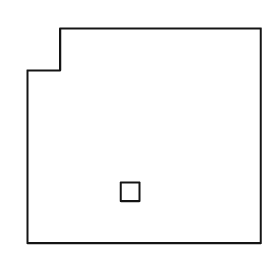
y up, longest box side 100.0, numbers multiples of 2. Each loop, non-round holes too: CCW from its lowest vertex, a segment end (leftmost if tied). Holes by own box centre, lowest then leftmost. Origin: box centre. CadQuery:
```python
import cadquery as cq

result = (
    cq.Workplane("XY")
    .moveTo(-50.0, -46.0)
    .lineTo(50.0, -46.0)
    .lineTo(50.0, 46.0)
    .lineTo(-36.0, 46.0)
    .lineTo(-36.0, 28.0)
    .lineTo(-50.0, 28.0)
    .close()
    .moveTo(-10.0, -28.0)
    .lineTo(-2.0, -28.0)
    .lineTo(-2.0, -20.0)
    .lineTo(-10.0, -20.0)
    .close()
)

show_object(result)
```